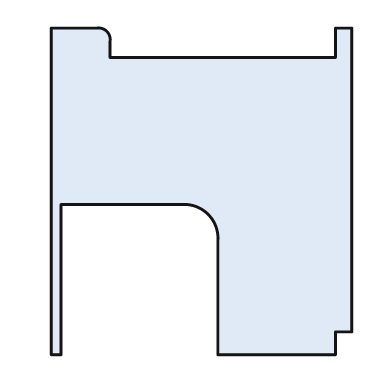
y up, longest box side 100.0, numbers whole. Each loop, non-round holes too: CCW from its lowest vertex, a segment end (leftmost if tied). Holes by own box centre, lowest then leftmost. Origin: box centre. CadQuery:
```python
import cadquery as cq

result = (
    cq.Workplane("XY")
    .moveTo(-46.0, -50.0)
    .lineTo(-43.0, -50.0)
    .lineTo(-43.0, -4.0)
    .lineTo(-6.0, -4.0)
    .threePointArc((2.0, -7.0), (5.0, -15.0))
    .lineTo(5.0, -50.0)
    .lineTo(41.0, -50.0)
    .lineTo(41.0, -43.0)
    .lineTo(46.0, -43.0)
    .lineTo(46.0, 50.0)
    .lineTo(41.0, 50.0)
    .lineTo(41.0, 41.0)
    .lineTo(-28.0, 41.0)
    .lineTo(-28.0, 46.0)
    .threePointArc((-29.0, 49.0), (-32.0, 50.0))
    .lineTo(-46.0, 50.0)
    .close()
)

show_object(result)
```